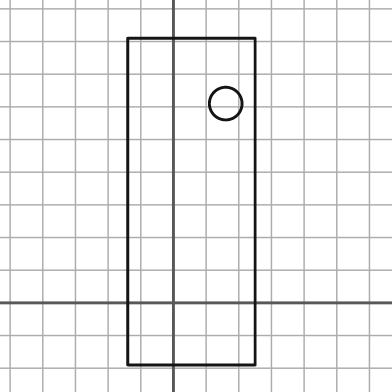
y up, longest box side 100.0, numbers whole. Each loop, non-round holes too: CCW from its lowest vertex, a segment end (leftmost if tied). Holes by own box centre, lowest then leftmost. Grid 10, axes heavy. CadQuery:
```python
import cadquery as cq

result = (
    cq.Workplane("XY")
    .moveTo(-14.0, -19.0)
    .lineTo(25.0, -19.0)
    .lineTo(25.0, 81.0)
    .lineTo(-14.0, 81.0)
    .close()
    .moveTo(16.0, 61.0)
    .circle(5.0)
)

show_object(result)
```